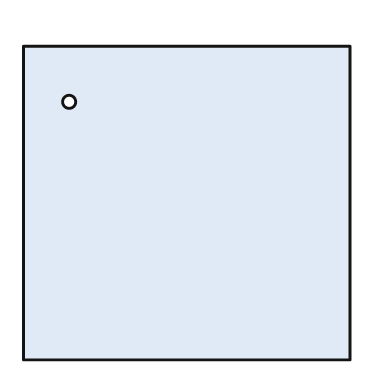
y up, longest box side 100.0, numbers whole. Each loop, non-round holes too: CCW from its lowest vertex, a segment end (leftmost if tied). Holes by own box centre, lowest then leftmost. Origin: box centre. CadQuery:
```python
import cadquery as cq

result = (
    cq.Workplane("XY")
    .moveTo(-50.0, -48.0)
    .lineTo(50.0, -48.0)
    .lineTo(50.0, 48.0)
    .lineTo(-50.0, 48.0)
    .close()
    .moveTo(-36.0, 31.0)
    .circle(2.0)
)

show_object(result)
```